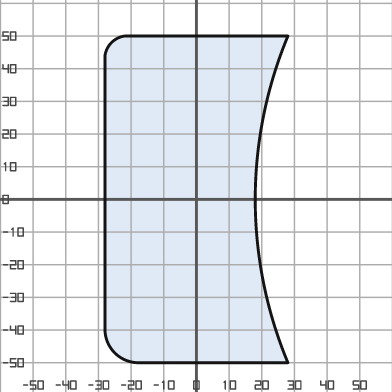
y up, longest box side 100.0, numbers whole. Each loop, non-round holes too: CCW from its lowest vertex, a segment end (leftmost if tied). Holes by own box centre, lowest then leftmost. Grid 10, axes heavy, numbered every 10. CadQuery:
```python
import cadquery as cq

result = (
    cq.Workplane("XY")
    .moveTo(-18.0, -50.0)
    .lineTo(28.0, -50.0)
    .threePointArc((18.0, 0.0), (28.0, 50.0))
    .lineTo(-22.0, 50.0)
    .threePointArc((-26.0, 48.0), (-28.0, 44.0))
    .lineTo(-28.0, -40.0)
    .threePointArc((-25.0, -47.0), (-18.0, -50.0))
    .close()
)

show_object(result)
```